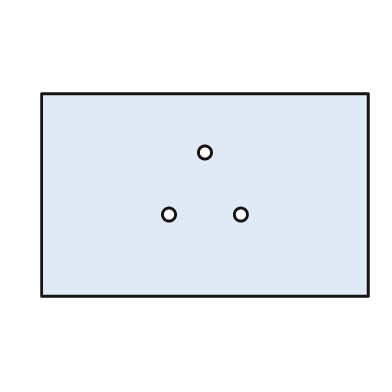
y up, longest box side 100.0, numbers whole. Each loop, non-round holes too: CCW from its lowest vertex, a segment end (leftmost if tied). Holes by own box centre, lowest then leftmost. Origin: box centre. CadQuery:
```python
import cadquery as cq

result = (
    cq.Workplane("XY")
    .moveTo(-50.0, -31.0)
    .lineTo(50.0, -31.0)
    .lineTo(50.0, 31.0)
    .lineTo(-50.0, 31.0)
    .close()
    .moveTo(-11.0, -6.0)
    .circle(2.0)
    .moveTo(11.0, -6.0)
    .circle(2.0)
    .moveTo(0.0, 13.0)
    .circle(2.0)
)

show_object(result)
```